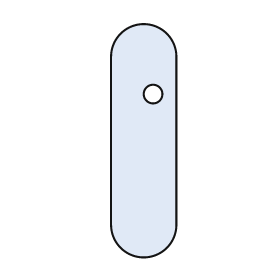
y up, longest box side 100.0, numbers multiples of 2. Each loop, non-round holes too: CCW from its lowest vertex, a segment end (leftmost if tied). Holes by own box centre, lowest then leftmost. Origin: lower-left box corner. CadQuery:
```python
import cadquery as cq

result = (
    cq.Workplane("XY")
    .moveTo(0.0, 14.0)
    .threePointArc((14.0, 0.0), (28.0, 14.0))
    .lineTo(28.0, 86.0)
    .threePointArc((14.0, 100.0), (0.0, 86.0))
    .close()
    .moveTo(18.0, 70.0)
    .circle(4.0)
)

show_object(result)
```